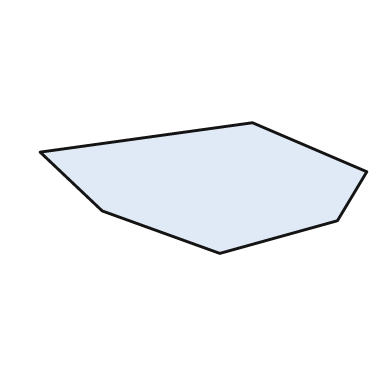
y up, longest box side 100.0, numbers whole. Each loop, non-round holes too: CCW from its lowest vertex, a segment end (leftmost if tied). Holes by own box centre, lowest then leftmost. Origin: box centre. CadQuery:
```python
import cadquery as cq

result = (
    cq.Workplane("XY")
    .moveTo(5.0, -20.0)
    .lineTo(41.0, -10.0)
    .lineTo(50.0, 5.0)
    .lineTo(15.0, 20.0)
    .lineTo(-50.0, 11.0)
    .lineTo(-31.0, -7.0)
    .close()
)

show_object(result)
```